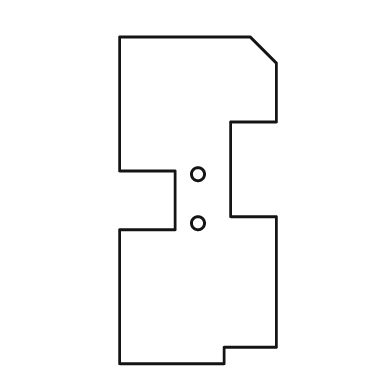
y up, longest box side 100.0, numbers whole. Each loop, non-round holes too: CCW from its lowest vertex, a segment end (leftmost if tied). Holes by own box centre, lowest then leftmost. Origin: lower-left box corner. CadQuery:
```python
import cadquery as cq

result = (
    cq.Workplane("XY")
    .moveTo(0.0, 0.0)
    .lineTo(32.0, 0.0)
    .lineTo(32.0, 5.0)
    .lineTo(48.0, 5.0)
    .lineTo(48.0, 45.0)
    .lineTo(34.0, 45.0)
    .lineTo(34.0, 74.0)
    .lineTo(48.0, 74.0)
    .lineTo(48.0, 92.0)
    .lineTo(40.0, 100.0)
    .lineTo(0.0, 100.0)
    .lineTo(0.0, 59.0)
    .lineTo(17.0, 59.0)
    .lineTo(17.0, 41.0)
    .lineTo(0.0, 41.0)
    .close()
    .moveTo(24.0, 43.0)
    .circle(2.0)
    .moveTo(24.0, 58.0)
    .circle(2.0)
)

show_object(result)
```